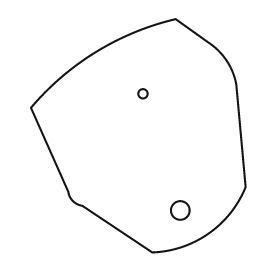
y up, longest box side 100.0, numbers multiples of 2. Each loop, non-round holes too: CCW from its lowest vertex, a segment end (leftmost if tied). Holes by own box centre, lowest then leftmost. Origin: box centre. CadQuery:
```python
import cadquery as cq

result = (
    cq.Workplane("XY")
    .moveTo(6.0, -50.0)
    .threePointArc((30.0, -42.0), (46.0, -22.0))
    .lineTo(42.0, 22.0)
    .threePointArc((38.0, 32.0), (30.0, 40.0))
    .lineTo(16.0, 50.0)
    .threePointArc((-18.0, 36.0), (-46.0, 12.0))
    .lineTo(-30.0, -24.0)
    .threePointArc((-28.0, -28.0), (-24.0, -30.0))
    .close()
    .moveTo(18.0, -32.0)
    .circle(4.0)
    .moveTo(2.0, 18.0)
    .circle(2.0)
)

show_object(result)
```